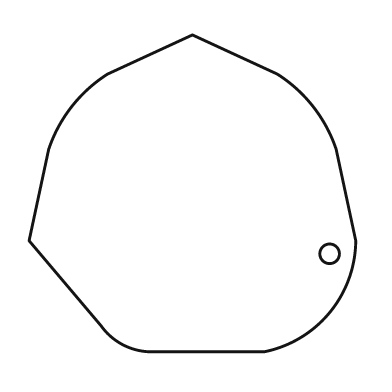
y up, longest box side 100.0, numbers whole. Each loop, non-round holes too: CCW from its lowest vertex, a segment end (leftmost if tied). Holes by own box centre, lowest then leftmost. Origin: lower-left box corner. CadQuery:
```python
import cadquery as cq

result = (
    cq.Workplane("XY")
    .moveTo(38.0, 0.0)
    .lineTo(72.0, 0.0)
    .threePointArc((92.0, 12.0), (100.0, 34.0))
    .lineTo(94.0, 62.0)
    .threePointArc((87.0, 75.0), (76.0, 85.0))
    .lineTo(50.0, 97.0)
    .lineTo(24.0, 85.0)
    .threePointArc((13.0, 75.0), (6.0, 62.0))
    .lineTo(0.0, 34.0)
    .lineTo(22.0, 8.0)
    .threePointArc((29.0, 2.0), (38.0, 0.0))
    .close()
    .moveTo(92.0, 30.0)
    .circle(3.0)
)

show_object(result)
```